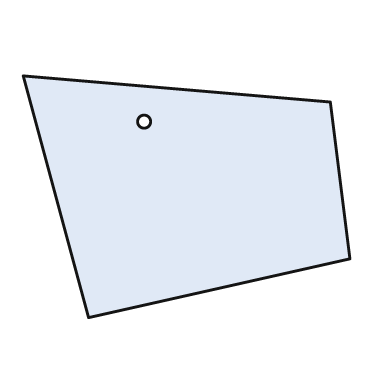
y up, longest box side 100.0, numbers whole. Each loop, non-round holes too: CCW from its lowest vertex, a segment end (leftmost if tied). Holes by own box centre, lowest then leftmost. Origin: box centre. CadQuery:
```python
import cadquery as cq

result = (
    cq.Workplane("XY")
    .moveTo(-30.0, -37.0)
    .lineTo(50.0, -19.0)
    .lineTo(44.0, 29.0)
    .lineTo(-50.0, 37.0)
    .close()
    .moveTo(-13.0, 23.0)
    .circle(2.0)
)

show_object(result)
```